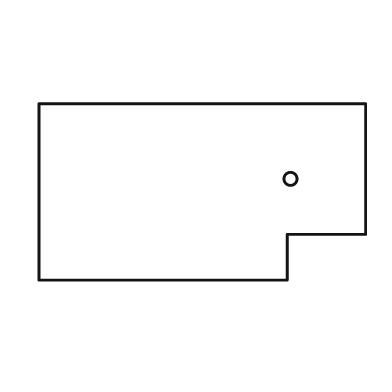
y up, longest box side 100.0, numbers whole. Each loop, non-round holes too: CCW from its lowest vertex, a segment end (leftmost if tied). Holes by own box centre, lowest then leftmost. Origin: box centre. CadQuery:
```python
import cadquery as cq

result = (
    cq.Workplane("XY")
    .moveTo(-50.0, -27.0)
    .lineTo(26.0, -27.0)
    .lineTo(26.0, -13.0)
    .lineTo(50.0, -13.0)
    .lineTo(50.0, 27.0)
    .lineTo(-50.0, 27.0)
    .close()
    .moveTo(27.0, 4.0)
    .circle(2.0)
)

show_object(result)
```